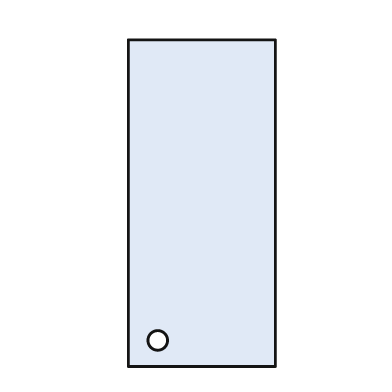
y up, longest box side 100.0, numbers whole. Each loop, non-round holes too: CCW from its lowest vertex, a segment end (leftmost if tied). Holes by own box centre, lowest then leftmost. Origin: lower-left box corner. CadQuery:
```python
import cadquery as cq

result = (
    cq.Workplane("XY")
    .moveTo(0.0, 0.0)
    .lineTo(45.0, 0.0)
    .lineTo(45.0, 100.0)
    .lineTo(0.0, 100.0)
    .close()
    .moveTo(9.0, 8.0)
    .circle(3.0)
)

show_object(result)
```